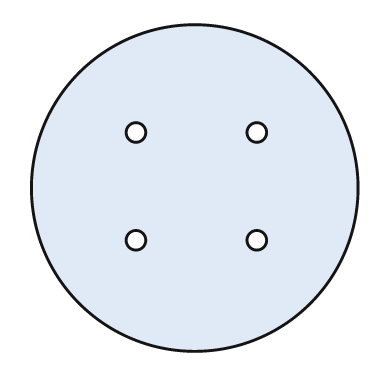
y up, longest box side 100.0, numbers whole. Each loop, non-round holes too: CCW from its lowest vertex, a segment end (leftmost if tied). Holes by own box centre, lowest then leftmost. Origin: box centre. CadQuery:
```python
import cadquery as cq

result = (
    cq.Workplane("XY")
    .moveTo(0.0, 0.0)
    .circle(50.0)
    .moveTo(-18.0, -16.0)
    .circle(3.0)
    .moveTo(19.0, -16.0)
    .circle(3.0)
    .moveTo(-18.0, 17.0)
    .circle(3.0)
    .moveTo(19.0, 17.0)
    .circle(3.0)
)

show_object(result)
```